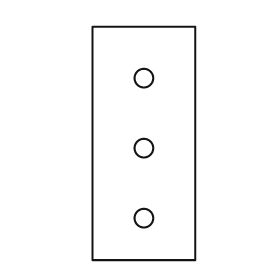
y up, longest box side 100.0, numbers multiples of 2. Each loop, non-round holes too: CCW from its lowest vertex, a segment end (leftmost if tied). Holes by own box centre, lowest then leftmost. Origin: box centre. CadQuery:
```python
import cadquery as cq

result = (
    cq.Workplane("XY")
    .moveTo(-22.0, -50.0)
    .lineTo(22.0, -50.0)
    .lineTo(22.0, 50.0)
    .lineTo(-22.0, 50.0)
    .close()
    .moveTo(0.0, -32.0)
    .circle(4.0)
    .moveTo(0.0, -2.0)
    .circle(4.0)
    .moveTo(0.0, 28.0)
    .circle(4.0)
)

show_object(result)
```